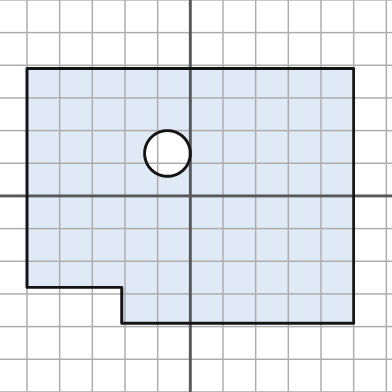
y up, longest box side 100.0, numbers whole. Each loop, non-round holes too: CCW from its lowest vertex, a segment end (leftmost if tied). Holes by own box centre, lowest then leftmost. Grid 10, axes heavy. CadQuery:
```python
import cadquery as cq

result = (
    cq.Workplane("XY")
    .moveTo(-21.0, -39.0)
    .lineTo(50.0, -39.0)
    .lineTo(50.0, 39.0)
    .lineTo(-50.0, 39.0)
    .lineTo(-50.0, -28.0)
    .lineTo(-21.0, -28.0)
    .close()
    .moveTo(-7.0, 13.0)
    .circle(7.0)
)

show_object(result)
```